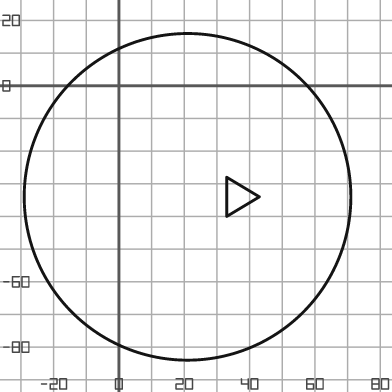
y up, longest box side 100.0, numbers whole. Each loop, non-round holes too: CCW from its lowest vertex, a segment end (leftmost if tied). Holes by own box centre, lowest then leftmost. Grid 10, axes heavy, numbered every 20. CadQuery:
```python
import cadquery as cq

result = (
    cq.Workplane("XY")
    .moveTo(21.0, -34.0)
    .circle(50.0)
    .moveTo(33.0, -40.0)
    .lineTo(43.0, -34.0)
    .lineTo(33.0, -28.0)
    .close()
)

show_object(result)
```